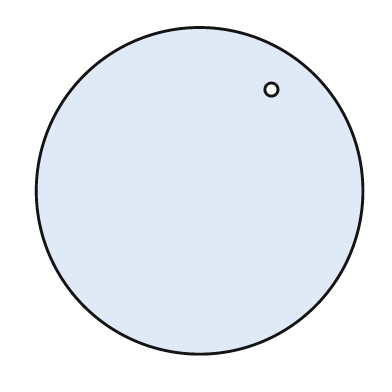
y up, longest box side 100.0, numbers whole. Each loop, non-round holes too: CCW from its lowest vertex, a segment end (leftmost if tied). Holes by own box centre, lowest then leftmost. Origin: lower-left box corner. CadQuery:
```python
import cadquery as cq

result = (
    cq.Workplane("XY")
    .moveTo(50.0, 50.0)
    .circle(50.0)
    .moveTo(72.0, 81.0)
    .circle(2.0)
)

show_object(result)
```